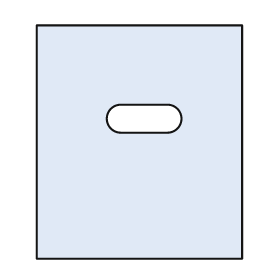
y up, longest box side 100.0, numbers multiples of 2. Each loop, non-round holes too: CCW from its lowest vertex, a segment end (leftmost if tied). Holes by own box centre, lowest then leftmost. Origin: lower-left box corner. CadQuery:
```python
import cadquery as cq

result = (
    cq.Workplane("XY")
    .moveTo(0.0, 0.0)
    .lineTo(88.0, 0.0)
    .lineTo(88.0, 100.0)
    .lineTo(0.0, 100.0)
    .close()
    .moveTo(36.0, 54.0)
    .lineTo(56.0, 54.0)
    .threePointArc((62.0, 60.0), (56.0, 66.0))
    .lineTo(36.0, 66.0)
    .threePointArc((30.0, 60.0), (36.0, 54.0))
    .close()
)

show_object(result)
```